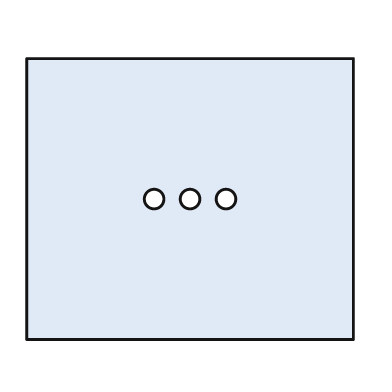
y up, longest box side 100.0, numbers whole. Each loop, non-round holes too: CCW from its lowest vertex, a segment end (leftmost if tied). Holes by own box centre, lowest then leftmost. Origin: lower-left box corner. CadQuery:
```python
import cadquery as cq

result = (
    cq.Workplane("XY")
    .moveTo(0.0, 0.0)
    .lineTo(100.0, 0.0)
    .lineTo(100.0, 86.0)
    .lineTo(0.0, 86.0)
    .close()
    .moveTo(39.0, 43.0)
    .circle(3.0)
    .moveTo(50.0, 43.0)
    .circle(3.0)
    .moveTo(61.0, 43.0)
    .circle(3.0)
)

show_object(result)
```